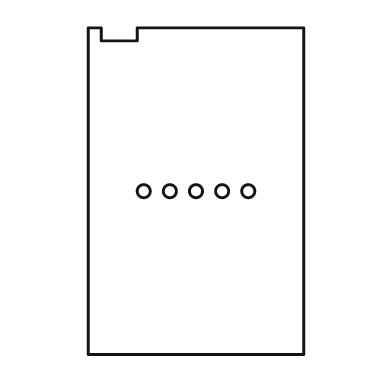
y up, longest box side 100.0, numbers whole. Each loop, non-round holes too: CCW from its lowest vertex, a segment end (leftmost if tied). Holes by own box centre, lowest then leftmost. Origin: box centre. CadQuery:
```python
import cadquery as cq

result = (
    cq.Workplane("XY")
    .moveTo(-33.0, -50.0)
    .lineTo(33.0, -50.0)
    .lineTo(33.0, 50.0)
    .lineTo(-18.0, 50.0)
    .lineTo(-18.0, 46.0)
    .lineTo(-29.0, 46.0)
    .lineTo(-29.0, 50.0)
    .lineTo(-33.0, 50.0)
    .close()
    .moveTo(-16.0, 0.0)
    .circle(2.0)
    .moveTo(-8.0, 0.0)
    .circle(2.0)
    .moveTo(0.0, 0.0)
    .circle(2.0)
    .moveTo(8.0, 0.0)
    .circle(2.0)
    .moveTo(16.0, 0.0)
    .circle(2.0)
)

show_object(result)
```